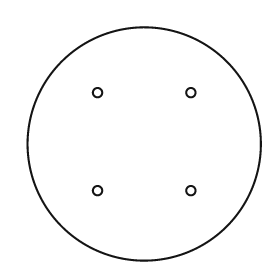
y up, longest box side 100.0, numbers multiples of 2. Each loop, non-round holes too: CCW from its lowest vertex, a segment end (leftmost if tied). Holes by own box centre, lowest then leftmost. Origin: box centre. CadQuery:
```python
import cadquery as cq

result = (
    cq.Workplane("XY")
    .moveTo(0.0, 0.0)
    .circle(50.0)
    .moveTo(-20.0, -20.0)
    .circle(2.0)
    .moveTo(20.0, -20.0)
    .circle(2.0)
    .moveTo(-20.0, 22.0)
    .circle(2.0)
    .moveTo(20.0, 22.0)
    .circle(2.0)
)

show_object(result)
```